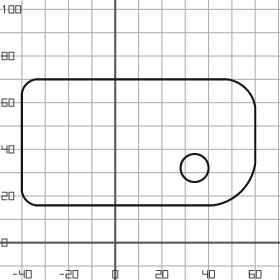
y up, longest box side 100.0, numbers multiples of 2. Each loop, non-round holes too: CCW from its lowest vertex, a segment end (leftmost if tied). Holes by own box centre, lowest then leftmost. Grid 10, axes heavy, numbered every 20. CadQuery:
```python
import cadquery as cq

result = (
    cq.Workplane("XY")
    .moveTo(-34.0, 16.0)
    .lineTo(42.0, 16.0)
    .threePointArc((54.0, 22.0), (60.0, 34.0))
    .lineTo(60.0, 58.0)
    .threePointArc((56.0, 66.0), (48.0, 70.0))
    .lineTo(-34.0, 70.0)
    .threePointArc((-38.0, 68.0), (-40.0, 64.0))
    .lineTo(-40.0, 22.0)
    .threePointArc((-38.0, 18.0), (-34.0, 16.0))
    .close()
    .moveTo(34.0, 32.0)
    .circle(6.0)
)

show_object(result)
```